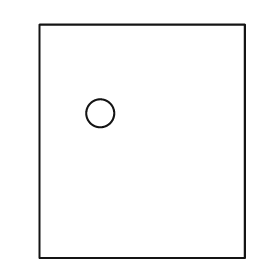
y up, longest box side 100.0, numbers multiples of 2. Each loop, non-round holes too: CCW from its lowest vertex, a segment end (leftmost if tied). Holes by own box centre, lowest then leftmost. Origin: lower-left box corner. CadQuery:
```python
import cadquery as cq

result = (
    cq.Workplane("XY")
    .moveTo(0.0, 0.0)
    .lineTo(88.0, 0.0)
    .lineTo(88.0, 100.0)
    .lineTo(0.0, 100.0)
    .close()
    .moveTo(26.0, 62.0)
    .circle(6.0)
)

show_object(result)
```